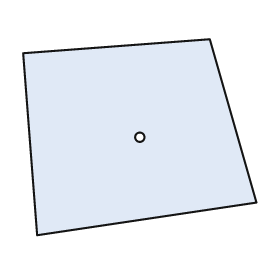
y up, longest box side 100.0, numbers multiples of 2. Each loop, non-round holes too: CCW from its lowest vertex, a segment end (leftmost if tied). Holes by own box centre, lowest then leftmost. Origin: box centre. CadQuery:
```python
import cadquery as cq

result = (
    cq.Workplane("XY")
    .moveTo(-44.0, -42.0)
    .lineTo(50.0, -28.0)
    .lineTo(30.0, 42.0)
    .lineTo(-50.0, 36.0)
    .close()
    .moveTo(0.0, 0.0)
    .circle(2.0)
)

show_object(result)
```